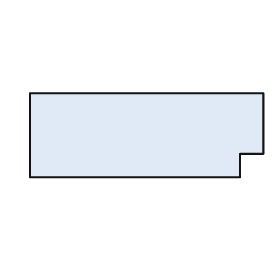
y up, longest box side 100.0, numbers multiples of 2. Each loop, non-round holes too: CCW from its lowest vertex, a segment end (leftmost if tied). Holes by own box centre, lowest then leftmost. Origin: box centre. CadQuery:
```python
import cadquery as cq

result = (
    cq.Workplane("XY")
    .moveTo(-50.0, -18.0)
    .lineTo(40.0, -18.0)
    .lineTo(40.0, -8.0)
    .lineTo(50.0, -8.0)
    .lineTo(50.0, 18.0)
    .lineTo(-50.0, 18.0)
    .close()
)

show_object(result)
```